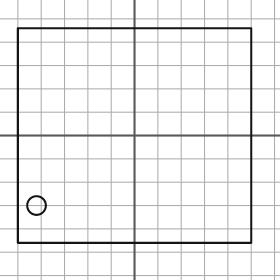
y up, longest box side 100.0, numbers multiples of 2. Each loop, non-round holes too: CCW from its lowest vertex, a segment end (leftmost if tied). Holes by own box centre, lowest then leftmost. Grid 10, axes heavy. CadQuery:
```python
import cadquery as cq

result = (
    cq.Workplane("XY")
    .moveTo(-50.0, -46.0)
    .lineTo(50.0, -46.0)
    .lineTo(50.0, 46.0)
    .lineTo(-50.0, 46.0)
    .close()
    .moveTo(-42.0, -30.0)
    .circle(4.0)
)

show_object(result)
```